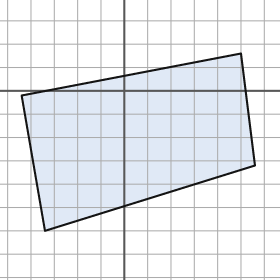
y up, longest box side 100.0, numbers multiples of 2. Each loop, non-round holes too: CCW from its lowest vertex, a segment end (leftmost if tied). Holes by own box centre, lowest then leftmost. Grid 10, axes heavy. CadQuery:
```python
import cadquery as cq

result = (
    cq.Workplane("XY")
    .moveTo(-34.0, -60.0)
    .lineTo(56.0, -32.0)
    .lineTo(50.0, 16.0)
    .lineTo(-44.0, -2.0)
    .close()
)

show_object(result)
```